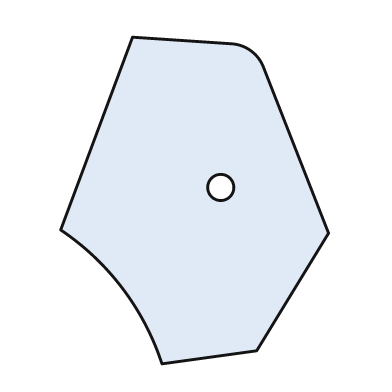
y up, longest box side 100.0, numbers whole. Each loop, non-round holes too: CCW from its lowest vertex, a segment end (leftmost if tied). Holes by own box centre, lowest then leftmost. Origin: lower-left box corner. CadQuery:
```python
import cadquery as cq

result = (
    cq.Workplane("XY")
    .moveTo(31.0, 0.0)
    .lineTo(60.0, 4.0)
    .lineTo(82.0, 40.0)
    .lineTo(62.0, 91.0)
    .threePointArc((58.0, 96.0), (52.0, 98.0))
    .lineTo(22.0, 100.0)
    .lineTo(0.0, 41.0)
    .threePointArc((19.0, 23.0), (31.0, 0.0))
    .close()
    .moveTo(49.0, 54.0)
    .circle(4.0)
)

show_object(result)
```